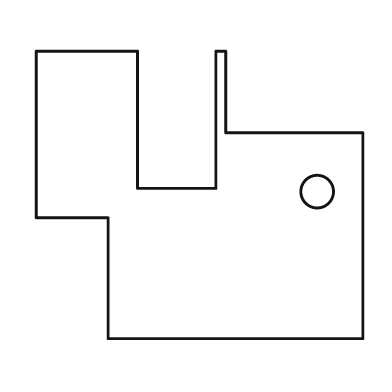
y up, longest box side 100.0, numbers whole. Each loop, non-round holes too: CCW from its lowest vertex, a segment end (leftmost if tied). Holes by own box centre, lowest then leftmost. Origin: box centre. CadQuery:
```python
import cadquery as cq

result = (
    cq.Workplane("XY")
    .moveTo(-28.0, -44.0)
    .lineTo(50.0, -44.0)
    .lineTo(50.0, 19.0)
    .lineTo(8.0, 19.0)
    .lineTo(8.0, 44.0)
    .lineTo(5.0, 44.0)
    .lineTo(5.0, 2.0)
    .lineTo(-19.0, 2.0)
    .lineTo(-19.0, 44.0)
    .lineTo(-50.0, 44.0)
    .lineTo(-50.0, -7.0)
    .lineTo(-28.0, -7.0)
    .close()
    .moveTo(36.0, 1.0)
    .circle(5.0)
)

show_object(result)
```